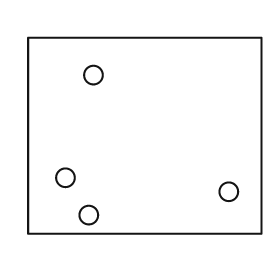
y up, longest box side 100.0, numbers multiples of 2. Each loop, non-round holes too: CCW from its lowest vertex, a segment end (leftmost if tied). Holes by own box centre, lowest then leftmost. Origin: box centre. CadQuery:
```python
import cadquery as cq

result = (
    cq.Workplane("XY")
    .moveTo(-50.0, -42.0)
    .lineTo(50.0, -42.0)
    .lineTo(50.0, 42.0)
    .lineTo(-50.0, 42.0)
    .close()
    .moveTo(-24.0, -34.0)
    .circle(4.0)
    .moveTo(36.0, -24.0)
    .circle(4.0)
    .moveTo(-34.0, -18.0)
    .circle(4.0)
    .moveTo(-22.0, 26.0)
    .circle(4.0)
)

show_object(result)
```